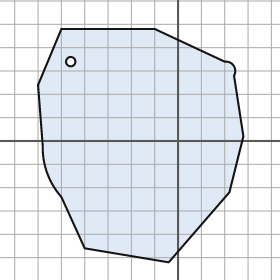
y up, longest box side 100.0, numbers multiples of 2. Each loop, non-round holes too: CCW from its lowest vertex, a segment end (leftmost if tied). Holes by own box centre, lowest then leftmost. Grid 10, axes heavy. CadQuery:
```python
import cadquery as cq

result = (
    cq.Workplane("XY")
    .moveTo(-4.0, -52.0)
    .lineTo(22.0, -22.0)
    .lineTo(28.0, 2.0)
    .lineTo(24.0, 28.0)
    .threePointArc((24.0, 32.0), (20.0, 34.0))
    .lineTo(-10.0, 48.0)
    .lineTo(-50.0, 48.0)
    .lineTo(-60.0, 24.0)
    .lineTo(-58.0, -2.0)
    .threePointArc((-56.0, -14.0), (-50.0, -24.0))
    .lineTo(-40.0, -46.0)
    .close()
    .moveTo(-46.0, 34.0)
    .circle(2.0)
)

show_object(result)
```